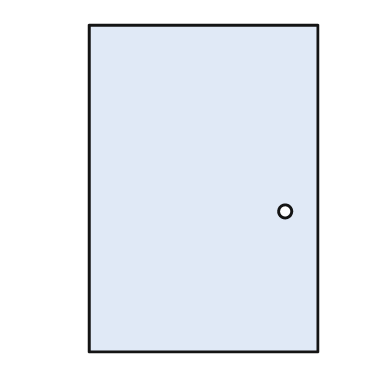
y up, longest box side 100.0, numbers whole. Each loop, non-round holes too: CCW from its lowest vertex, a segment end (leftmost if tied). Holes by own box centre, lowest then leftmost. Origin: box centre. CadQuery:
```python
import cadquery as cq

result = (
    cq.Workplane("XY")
    .moveTo(-35.0, -50.0)
    .lineTo(35.0, -50.0)
    .lineTo(35.0, 50.0)
    .lineTo(-35.0, 50.0)
    .close()
    .moveTo(25.0, -7.0)
    .circle(2.0)
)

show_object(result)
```